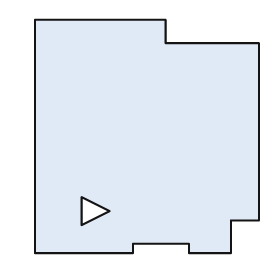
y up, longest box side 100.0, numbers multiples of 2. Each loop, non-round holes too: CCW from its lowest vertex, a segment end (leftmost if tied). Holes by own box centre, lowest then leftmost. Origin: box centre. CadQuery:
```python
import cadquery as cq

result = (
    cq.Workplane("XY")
    .moveTo(-48.0, -50.0)
    .lineTo(-6.0, -50.0)
    .lineTo(-6.0, -46.0)
    .lineTo(18.0, -46.0)
    .lineTo(18.0, -50.0)
    .lineTo(36.0, -50.0)
    .lineTo(36.0, -36.0)
    .lineTo(48.0, -36.0)
    .lineTo(48.0, 40.0)
    .lineTo(8.0, 40.0)
    .lineTo(8.0, 50.0)
    .lineTo(-48.0, 50.0)
    .close()
    .moveTo(-28.0, -38.0)
    .lineTo(-16.0, -32.0)
    .lineTo(-28.0, -26.0)
    .close()
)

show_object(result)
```